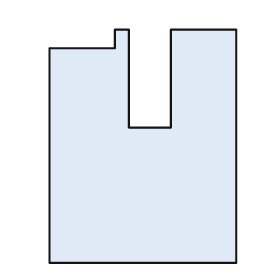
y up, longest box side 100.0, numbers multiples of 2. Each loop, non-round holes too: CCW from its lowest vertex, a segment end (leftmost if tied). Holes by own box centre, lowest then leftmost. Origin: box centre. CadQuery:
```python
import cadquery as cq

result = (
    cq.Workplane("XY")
    .moveTo(-40.0, -50.0)
    .lineTo(40.0, -50.0)
    .lineTo(40.0, 50.0)
    .lineTo(12.0, 50.0)
    .lineTo(12.0, 8.0)
    .lineTo(-6.0, 8.0)
    .lineTo(-6.0, 50.0)
    .lineTo(-12.0, 50.0)
    .lineTo(-12.0, 42.0)
    .lineTo(-40.0, 42.0)
    .close()
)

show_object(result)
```